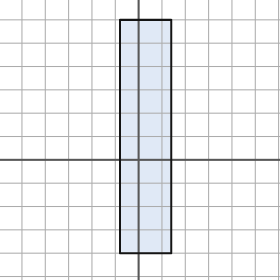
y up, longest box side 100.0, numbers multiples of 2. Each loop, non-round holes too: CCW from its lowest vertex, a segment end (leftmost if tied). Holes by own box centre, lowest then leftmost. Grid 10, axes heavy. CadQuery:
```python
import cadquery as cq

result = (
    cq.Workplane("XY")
    .moveTo(-8.0, -40.0)
    .lineTo(14.0, -40.0)
    .lineTo(14.0, 60.0)
    .lineTo(-8.0, 60.0)
    .close()
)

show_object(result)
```